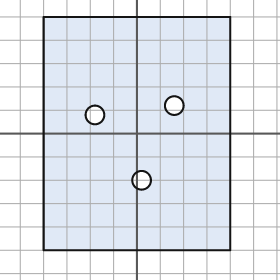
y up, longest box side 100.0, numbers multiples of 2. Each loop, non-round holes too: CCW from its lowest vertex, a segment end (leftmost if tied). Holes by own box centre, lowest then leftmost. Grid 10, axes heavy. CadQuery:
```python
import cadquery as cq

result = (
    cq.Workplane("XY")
    .moveTo(-40.0, -50.0)
    .lineTo(40.0, -50.0)
    .lineTo(40.0, 50.0)
    .lineTo(-40.0, 50.0)
    .close()
    .moveTo(2.0, -20.0)
    .circle(4.0)
    .moveTo(-18.0, 8.0)
    .circle(4.0)
    .moveTo(16.0, 12.0)
    .circle(4.0)
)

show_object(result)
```